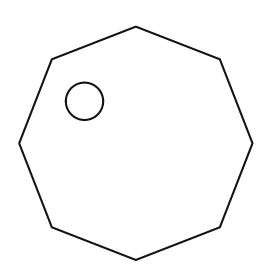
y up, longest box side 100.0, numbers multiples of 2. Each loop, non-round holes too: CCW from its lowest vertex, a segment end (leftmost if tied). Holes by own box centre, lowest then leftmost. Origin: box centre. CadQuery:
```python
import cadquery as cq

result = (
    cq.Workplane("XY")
    .moveTo(0.0, -50.0)
    .lineTo(36.0, -36.0)
    .lineTo(50.0, 0.0)
    .lineTo(36.0, 36.0)
    .lineTo(0.0, 50.0)
    .lineTo(-36.0, 36.0)
    .lineTo(-50.0, 0.0)
    .lineTo(-36.0, -36.0)
    .close()
    .moveTo(-22.0, 18.0)
    .circle(8.0)
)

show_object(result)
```